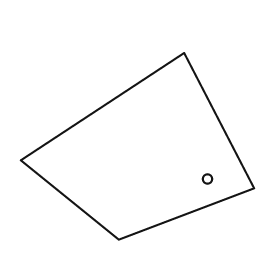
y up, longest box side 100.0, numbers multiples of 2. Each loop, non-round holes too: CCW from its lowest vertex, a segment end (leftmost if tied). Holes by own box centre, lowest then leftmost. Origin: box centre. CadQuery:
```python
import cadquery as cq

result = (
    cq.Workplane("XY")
    .moveTo(-8.0, -40.0)
    .lineTo(50.0, -18.0)
    .lineTo(20.0, 40.0)
    .lineTo(-50.0, -6.0)
    .close()
    .moveTo(30.0, -14.0)
    .circle(2.0)
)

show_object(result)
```